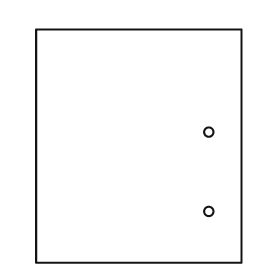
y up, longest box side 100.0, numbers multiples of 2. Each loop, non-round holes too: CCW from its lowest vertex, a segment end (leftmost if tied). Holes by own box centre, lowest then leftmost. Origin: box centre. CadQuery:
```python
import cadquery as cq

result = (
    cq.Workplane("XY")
    .moveTo(-44.0, -50.0)
    .lineTo(44.0, -50.0)
    .lineTo(44.0, 50.0)
    .lineTo(-44.0, 50.0)
    .close()
    .moveTo(30.0, -28.0)
    .circle(2.0)
    .moveTo(30.0, 6.0)
    .circle(2.0)
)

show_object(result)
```